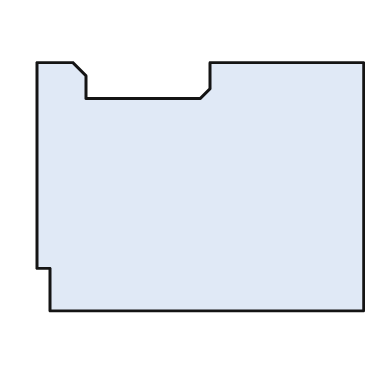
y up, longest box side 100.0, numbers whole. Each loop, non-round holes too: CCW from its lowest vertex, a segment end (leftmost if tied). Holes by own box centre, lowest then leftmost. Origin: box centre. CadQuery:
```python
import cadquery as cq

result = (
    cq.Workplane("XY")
    .moveTo(-46.0, -38.0)
    .lineTo(50.0, -38.0)
    .lineTo(50.0, 38.0)
    .lineTo(3.0, 38.0)
    .lineTo(3.0, 30.0)
    .lineTo(0.0, 27.0)
    .lineTo(-35.0, 27.0)
    .lineTo(-35.0, 34.0)
    .lineTo(-39.0, 38.0)
    .lineTo(-50.0, 38.0)
    .lineTo(-50.0, -25.0)
    .lineTo(-46.0, -25.0)
    .close()
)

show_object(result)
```